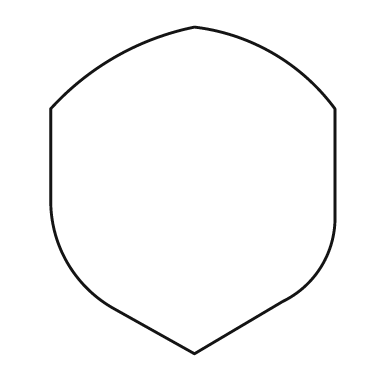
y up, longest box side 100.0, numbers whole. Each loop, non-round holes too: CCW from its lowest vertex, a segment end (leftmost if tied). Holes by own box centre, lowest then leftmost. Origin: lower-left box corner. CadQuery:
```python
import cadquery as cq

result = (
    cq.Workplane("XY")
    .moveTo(44.0, 0.0)
    .lineTo(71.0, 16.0)
    .threePointArc((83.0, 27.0), (87.0, 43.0))
    .lineTo(87.0, 75.0)
    .threePointArc((68.0, 92.0), (44.0, 100.0))
    .threePointArc((20.0, 91.0), (0.0, 75.0))
    .lineTo(0.0, 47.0)
    .threePointArc((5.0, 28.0), (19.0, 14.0))
    .close()
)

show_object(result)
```